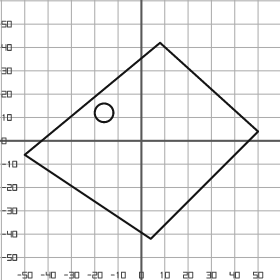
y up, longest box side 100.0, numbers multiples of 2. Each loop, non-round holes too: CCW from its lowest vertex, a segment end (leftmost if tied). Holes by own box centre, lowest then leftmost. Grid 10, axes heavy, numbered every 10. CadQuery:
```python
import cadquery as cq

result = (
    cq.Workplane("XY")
    .moveTo(4.0, -42.0)
    .lineTo(50.0, 4.0)
    .lineTo(8.0, 42.0)
    .lineTo(-50.0, -6.0)
    .close()
    .moveTo(-16.0, 12.0)
    .circle(4.0)
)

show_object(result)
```